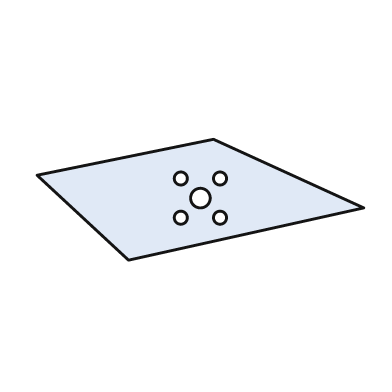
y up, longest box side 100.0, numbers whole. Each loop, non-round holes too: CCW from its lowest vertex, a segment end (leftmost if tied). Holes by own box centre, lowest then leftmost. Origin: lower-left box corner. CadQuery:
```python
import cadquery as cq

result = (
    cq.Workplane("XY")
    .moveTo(28.0, 0.0)
    .lineTo(100.0, 16.0)
    .lineTo(54.0, 37.0)
    .lineTo(0.0, 26.0)
    .close()
    .moveTo(44.0, 13.0)
    .circle(2.0)
    .moveTo(56.0, 13.0)
    .circle(2.0)
    .moveTo(50.0, 19.0)
    .circle(3.0)
    .moveTo(44.0, 25.0)
    .circle(2.0)
    .moveTo(56.0, 25.0)
    .circle(2.0)
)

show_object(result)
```